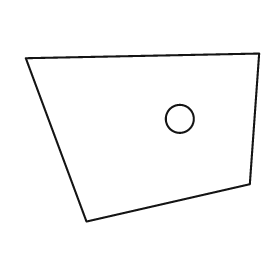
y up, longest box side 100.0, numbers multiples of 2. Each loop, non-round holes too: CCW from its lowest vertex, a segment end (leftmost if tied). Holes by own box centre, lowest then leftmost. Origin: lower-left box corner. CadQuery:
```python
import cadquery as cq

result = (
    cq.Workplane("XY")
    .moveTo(26.0, 0.0)
    .lineTo(96.0, 16.0)
    .lineTo(100.0, 72.0)
    .lineTo(0.0, 70.0)
    .close()
    .moveTo(66.0, 44.0)
    .circle(6.0)
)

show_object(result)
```